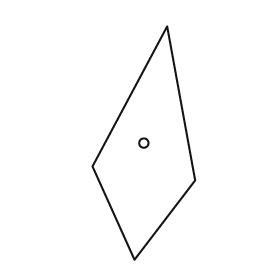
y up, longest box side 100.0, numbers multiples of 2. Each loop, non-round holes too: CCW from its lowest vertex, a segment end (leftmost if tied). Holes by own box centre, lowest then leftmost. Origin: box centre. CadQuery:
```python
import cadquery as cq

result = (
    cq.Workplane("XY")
    .moveTo(-4.0, -50.0)
    .lineTo(22.0, -16.0)
    .lineTo(10.0, 50.0)
    .lineTo(-22.0, -10.0)
    .close()
    .moveTo(0.0, 0.0)
    .circle(2.0)
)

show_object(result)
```